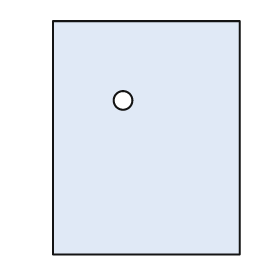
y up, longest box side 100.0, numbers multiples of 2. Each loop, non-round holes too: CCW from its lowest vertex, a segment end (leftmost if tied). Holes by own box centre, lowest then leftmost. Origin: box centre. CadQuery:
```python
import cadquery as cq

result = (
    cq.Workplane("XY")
    .moveTo(-40.0, -50.0)
    .lineTo(40.0, -50.0)
    .lineTo(40.0, 50.0)
    .lineTo(-40.0, 50.0)
    .close()
    .moveTo(-10.0, 16.0)
    .circle(4.0)
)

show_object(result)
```